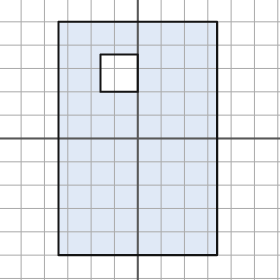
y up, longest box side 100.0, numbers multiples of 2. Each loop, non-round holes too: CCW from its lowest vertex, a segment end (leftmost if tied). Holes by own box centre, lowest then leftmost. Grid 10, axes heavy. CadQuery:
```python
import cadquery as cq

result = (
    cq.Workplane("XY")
    .moveTo(-34.0, -50.0)
    .lineTo(34.0, -50.0)
    .lineTo(34.0, 50.0)
    .lineTo(-34.0, 50.0)
    .close()
    .moveTo(-16.0, 20.0)
    .lineTo(0.0, 20.0)
    .lineTo(0.0, 36.0)
    .lineTo(-16.0, 36.0)
    .close()
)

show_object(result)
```